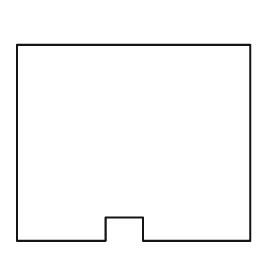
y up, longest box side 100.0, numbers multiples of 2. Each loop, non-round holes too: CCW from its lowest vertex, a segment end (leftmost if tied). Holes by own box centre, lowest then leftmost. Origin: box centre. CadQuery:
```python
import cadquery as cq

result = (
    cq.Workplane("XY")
    .moveTo(-50.0, -42.0)
    .lineTo(-12.0, -42.0)
    .lineTo(-12.0, -32.0)
    .lineTo(4.0, -32.0)
    .lineTo(4.0, -42.0)
    .lineTo(50.0, -42.0)
    .lineTo(50.0, 42.0)
    .lineTo(-50.0, 42.0)
    .close()
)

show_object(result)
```